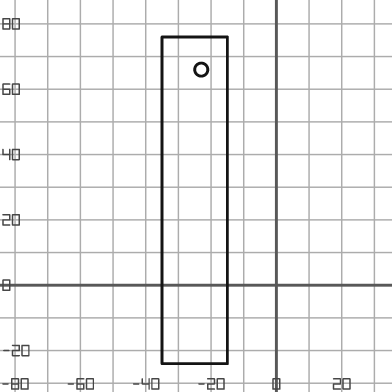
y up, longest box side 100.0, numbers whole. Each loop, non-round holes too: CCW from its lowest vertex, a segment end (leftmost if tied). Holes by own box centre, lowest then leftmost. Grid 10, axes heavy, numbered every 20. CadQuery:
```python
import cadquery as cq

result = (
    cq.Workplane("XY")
    .moveTo(-35.0, -24.0)
    .lineTo(-15.0, -24.0)
    .lineTo(-15.0, 76.0)
    .lineTo(-35.0, 76.0)
    .close()
    .moveTo(-23.0, 66.0)
    .circle(2.0)
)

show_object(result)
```